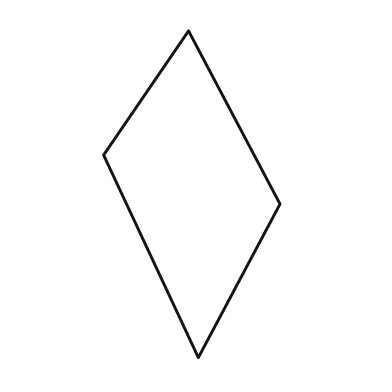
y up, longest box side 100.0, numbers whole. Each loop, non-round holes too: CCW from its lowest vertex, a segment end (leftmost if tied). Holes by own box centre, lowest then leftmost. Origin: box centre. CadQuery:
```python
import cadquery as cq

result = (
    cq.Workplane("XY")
    .moveTo(2.0, -50.0)
    .lineTo(27.0, -3.0)
    .lineTo(-1.0, 50.0)
    .lineTo(-27.0, 12.0)
    .close()
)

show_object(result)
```